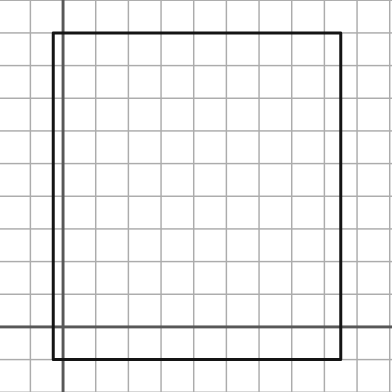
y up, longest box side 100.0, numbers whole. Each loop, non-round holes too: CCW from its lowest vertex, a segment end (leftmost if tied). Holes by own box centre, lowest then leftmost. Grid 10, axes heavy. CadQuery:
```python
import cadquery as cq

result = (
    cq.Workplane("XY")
    .moveTo(-3.0, -10.0)
    .lineTo(85.0, -10.0)
    .lineTo(85.0, 90.0)
    .lineTo(-3.0, 90.0)
    .close()
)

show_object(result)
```